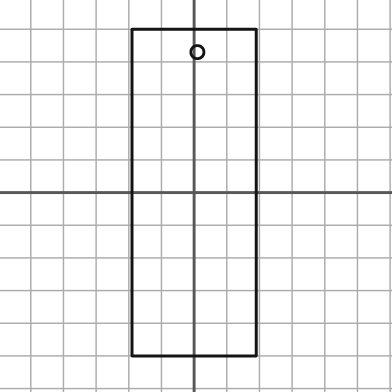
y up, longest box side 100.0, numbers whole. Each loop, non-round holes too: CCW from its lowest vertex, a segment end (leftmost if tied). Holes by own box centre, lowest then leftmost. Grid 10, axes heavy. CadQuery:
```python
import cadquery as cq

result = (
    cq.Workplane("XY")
    .moveTo(-19.0, -50.0)
    .lineTo(19.0, -50.0)
    .lineTo(19.0, 50.0)
    .lineTo(-19.0, 50.0)
    .close()
    .moveTo(1.0, 43.0)
    .circle(2.0)
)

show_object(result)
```